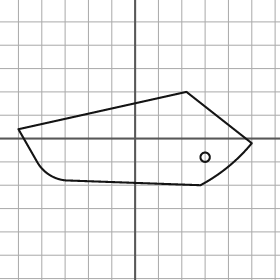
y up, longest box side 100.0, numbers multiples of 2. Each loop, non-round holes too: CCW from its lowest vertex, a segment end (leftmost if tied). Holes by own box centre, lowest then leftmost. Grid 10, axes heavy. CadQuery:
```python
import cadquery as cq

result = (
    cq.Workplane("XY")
    .moveTo(28.0, -20.0)
    .threePointArc((40.0, -12.0), (50.0, -2.0))
    .lineTo(22.0, 20.0)
    .lineTo(-50.0, 4.0)
    .lineTo(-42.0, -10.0)
    .threePointArc((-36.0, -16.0), (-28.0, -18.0))
    .close()
    .moveTo(30.0, -8.0)
    .circle(2.0)
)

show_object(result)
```